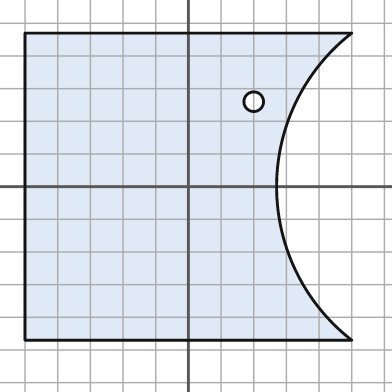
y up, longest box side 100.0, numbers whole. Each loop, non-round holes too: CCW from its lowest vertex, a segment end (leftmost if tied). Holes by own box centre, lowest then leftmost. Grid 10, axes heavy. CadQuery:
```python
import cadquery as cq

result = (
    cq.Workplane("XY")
    .moveTo(-50.0, -47.0)
    .lineTo(50.0, -47.0)
    .threePointArc((27.0, 0.0), (50.0, 47.0))
    .lineTo(-50.0, 47.0)
    .close()
    .moveTo(20.0, 26.0)
    .circle(3.0)
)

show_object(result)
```